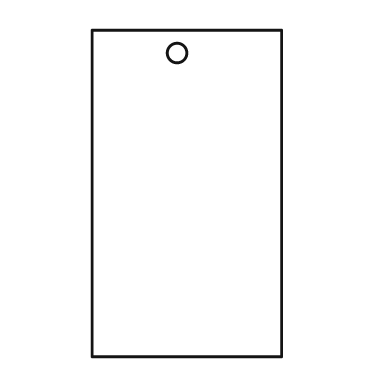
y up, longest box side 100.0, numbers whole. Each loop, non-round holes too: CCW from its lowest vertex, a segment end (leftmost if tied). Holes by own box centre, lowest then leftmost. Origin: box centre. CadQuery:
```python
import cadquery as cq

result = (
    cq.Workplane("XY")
    .moveTo(-29.0, -50.0)
    .lineTo(29.0, -50.0)
    .lineTo(29.0, 50.0)
    .lineTo(-29.0, 50.0)
    .close()
    .moveTo(-3.0, 43.0)
    .circle(3.0)
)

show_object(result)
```